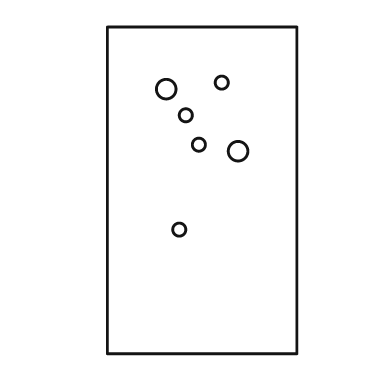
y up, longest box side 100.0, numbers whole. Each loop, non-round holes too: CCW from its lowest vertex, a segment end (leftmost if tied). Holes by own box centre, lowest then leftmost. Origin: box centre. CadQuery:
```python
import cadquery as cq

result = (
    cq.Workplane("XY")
    .moveTo(-29.0, -50.0)
    .lineTo(29.0, -50.0)
    .lineTo(29.0, 50.0)
    .lineTo(-29.0, 50.0)
    .close()
    .moveTo(-7.0, -12.0)
    .circle(2.0)
    .moveTo(11.0, 12.0)
    .circle(3.0)
    .moveTo(-1.0, 14.0)
    .circle(2.0)
    .moveTo(-5.0, 23.0)
    .circle(2.0)
    .moveTo(-11.0, 31.0)
    .circle(3.0)
    .moveTo(6.0, 33.0)
    .circle(2.0)
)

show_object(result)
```